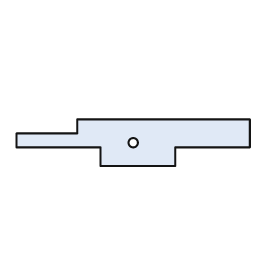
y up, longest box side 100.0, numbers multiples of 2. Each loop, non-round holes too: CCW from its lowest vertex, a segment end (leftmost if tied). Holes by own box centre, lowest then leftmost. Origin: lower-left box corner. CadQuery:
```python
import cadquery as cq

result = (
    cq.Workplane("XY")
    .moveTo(36.0, 0.0)
    .lineTo(68.0, 0.0)
    .lineTo(68.0, 8.0)
    .lineTo(100.0, 8.0)
    .lineTo(100.0, 20.0)
    .lineTo(26.0, 20.0)
    .lineTo(26.0, 14.0)
    .lineTo(0.0, 14.0)
    .lineTo(0.0, 8.0)
    .lineTo(36.0, 8.0)
    .close()
    .moveTo(50.0, 10.0)
    .circle(2.0)
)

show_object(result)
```